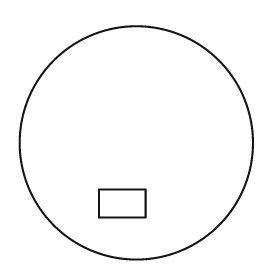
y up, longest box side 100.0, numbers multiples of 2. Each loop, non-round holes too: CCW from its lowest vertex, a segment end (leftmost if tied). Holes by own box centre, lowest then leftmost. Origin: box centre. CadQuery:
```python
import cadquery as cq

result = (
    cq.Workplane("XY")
    .moveTo(0.0, 0.0)
    .circle(50.0)
    .moveTo(-16.0, -32.0)
    .lineTo(4.0, -32.0)
    .lineTo(4.0, -20.0)
    .lineTo(-16.0, -20.0)
    .close()
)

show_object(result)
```